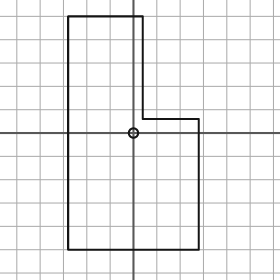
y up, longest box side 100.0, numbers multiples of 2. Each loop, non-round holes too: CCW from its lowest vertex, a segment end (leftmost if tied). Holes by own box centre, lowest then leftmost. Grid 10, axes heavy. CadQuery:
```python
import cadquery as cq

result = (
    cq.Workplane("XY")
    .moveTo(-28.0, -50.0)
    .lineTo(28.0, -50.0)
    .lineTo(28.0, 6.0)
    .lineTo(4.0, 6.0)
    .lineTo(4.0, 50.0)
    .lineTo(-28.0, 50.0)
    .close()
    .moveTo(0.0, 0.0)
    .circle(2.0)
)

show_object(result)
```